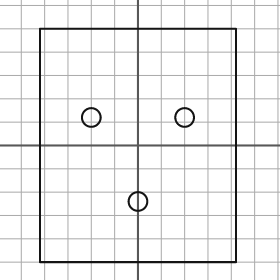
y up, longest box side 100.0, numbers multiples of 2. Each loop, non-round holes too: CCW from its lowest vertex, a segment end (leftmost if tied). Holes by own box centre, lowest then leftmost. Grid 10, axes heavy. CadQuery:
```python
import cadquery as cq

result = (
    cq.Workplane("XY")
    .moveTo(-42.0, -50.0)
    .lineTo(42.0, -50.0)
    .lineTo(42.0, 50.0)
    .lineTo(-42.0, 50.0)
    .close()
    .moveTo(0.0, -24.0)
    .circle(4.0)
    .moveTo(-20.0, 12.0)
    .circle(4.0)
    .moveTo(20.0, 12.0)
    .circle(4.0)
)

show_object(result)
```